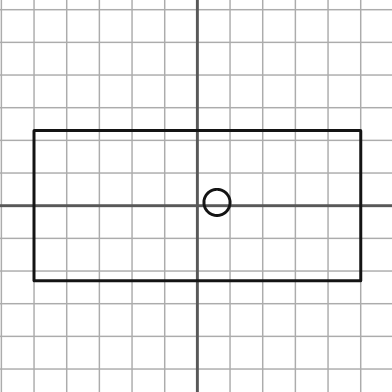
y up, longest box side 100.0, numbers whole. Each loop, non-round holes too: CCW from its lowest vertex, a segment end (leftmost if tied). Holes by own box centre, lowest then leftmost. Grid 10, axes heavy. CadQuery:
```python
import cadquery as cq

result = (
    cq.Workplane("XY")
    .moveTo(-50.0, -23.0)
    .lineTo(50.0, -23.0)
    .lineTo(50.0, 23.0)
    .lineTo(-50.0, 23.0)
    .close()
    .moveTo(6.0, 1.0)
    .circle(4.0)
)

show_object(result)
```